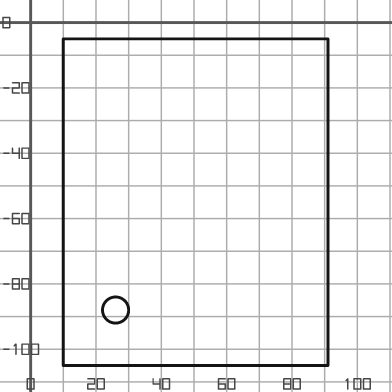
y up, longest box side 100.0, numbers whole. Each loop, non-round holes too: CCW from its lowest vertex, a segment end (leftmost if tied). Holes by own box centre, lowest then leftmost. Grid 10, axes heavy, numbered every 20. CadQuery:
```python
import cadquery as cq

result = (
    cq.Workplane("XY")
    .moveTo(10.0, -105.0)
    .lineTo(91.0, -105.0)
    .lineTo(91.0, -5.0)
    .lineTo(10.0, -5.0)
    .close()
    .moveTo(26.0, -88.0)
    .circle(4.0)
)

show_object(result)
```